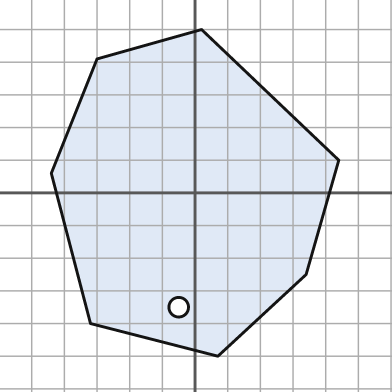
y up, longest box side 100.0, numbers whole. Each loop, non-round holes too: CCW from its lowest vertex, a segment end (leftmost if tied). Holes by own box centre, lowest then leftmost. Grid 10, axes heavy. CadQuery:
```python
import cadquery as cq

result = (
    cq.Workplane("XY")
    .moveTo(7.0, -50.0)
    .lineTo(34.0, -25.0)
    .lineTo(44.0, 10.0)
    .lineTo(2.0, 50.0)
    .lineTo(-30.0, 41.0)
    .lineTo(-44.0, 6.0)
    .lineTo(-32.0, -40.0)
    .close()
    .moveTo(-5.0, -35.0)
    .circle(3.0)
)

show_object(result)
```